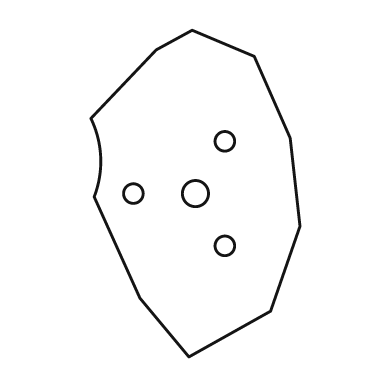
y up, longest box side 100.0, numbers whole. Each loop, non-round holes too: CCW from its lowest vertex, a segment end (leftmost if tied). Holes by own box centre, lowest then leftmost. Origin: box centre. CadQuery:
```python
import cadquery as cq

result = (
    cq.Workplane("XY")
    .moveTo(-2.0, -50.0)
    .lineTo(23.0, -36.0)
    .lineTo(32.0, -10.0)
    .lineTo(29.0, 17.0)
    .lineTo(18.0, 42.0)
    .lineTo(-1.0, 50.0)
    .lineTo(-12.0, 44.0)
    .lineTo(-32.0, 23.0)
    .threePointArc((-29.0, 11.0), (-31.0, -1.0))
    .lineTo(-17.0, -32.0)
    .close()
    .moveTo(9.0, -16.0)
    .circle(3.0)
    .moveTo(-19.0, 0.0)
    .circle(3.0)
    .moveTo(0.0, 0.0)
    .circle(4.0)
    .moveTo(9.0, 16.0)
    .circle(3.0)
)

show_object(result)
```